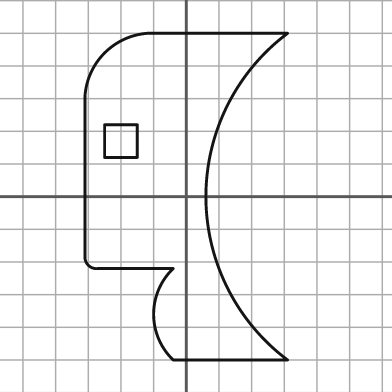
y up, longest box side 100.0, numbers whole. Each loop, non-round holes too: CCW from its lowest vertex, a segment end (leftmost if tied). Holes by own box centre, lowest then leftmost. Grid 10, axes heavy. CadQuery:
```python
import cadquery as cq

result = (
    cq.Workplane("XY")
    .moveTo(-4.0, -50.0)
    .lineTo(31.0, -50.0)
    .threePointArc((6.0, 0.0), (31.0, 50.0))
    .lineTo(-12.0, 50.0)
    .threePointArc((-25.0, 44.0), (-31.0, 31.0))
    .lineTo(-31.0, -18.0)
    .threePointArc((-30.0, -21.0), (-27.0, -22.0))
    .lineTo(-4.0, -22.0)
    .threePointArc((-10.0, -36.0), (-4.0, -50.0))
    .close()
    .moveTo(-25.0, 12.0)
    .lineTo(-15.0, 12.0)
    .lineTo(-15.0, 22.0)
    .lineTo(-25.0, 22.0)
    .close()
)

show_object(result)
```